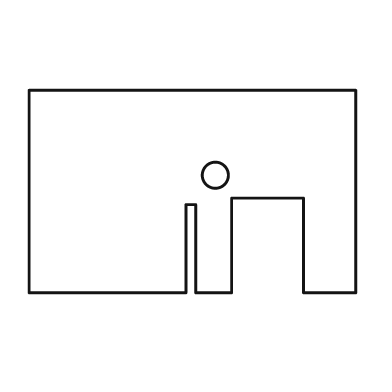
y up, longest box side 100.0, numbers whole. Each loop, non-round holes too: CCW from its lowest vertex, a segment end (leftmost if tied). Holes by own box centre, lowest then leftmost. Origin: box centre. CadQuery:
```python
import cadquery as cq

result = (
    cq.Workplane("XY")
    .moveTo(-50.0, -31.0)
    .lineTo(-2.0, -31.0)
    .lineTo(-2.0, -4.0)
    .lineTo(1.0, -4.0)
    .lineTo(1.0, -31.0)
    .lineTo(12.0, -31.0)
    .lineTo(12.0, -2.0)
    .lineTo(34.0, -2.0)
    .lineTo(34.0, -31.0)
    .lineTo(50.0, -31.0)
    .lineTo(50.0, 31.0)
    .lineTo(-50.0, 31.0)
    .close()
    .moveTo(7.0, 5.0)
    .circle(4.0)
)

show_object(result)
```